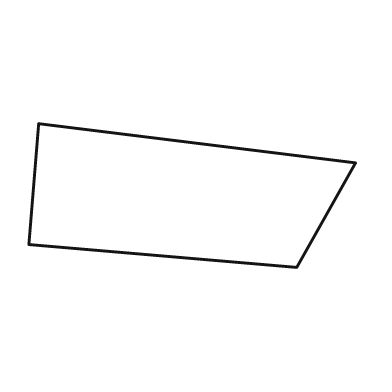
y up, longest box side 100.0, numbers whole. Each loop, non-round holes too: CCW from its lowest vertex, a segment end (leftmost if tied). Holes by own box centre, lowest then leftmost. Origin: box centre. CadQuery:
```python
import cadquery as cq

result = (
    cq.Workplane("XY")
    .moveTo(32.0, -22.0)
    .lineTo(50.0, 10.0)
    .lineTo(-47.0, 22.0)
    .lineTo(-50.0, -15.0)
    .close()
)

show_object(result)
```